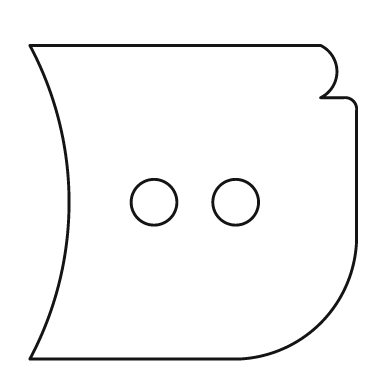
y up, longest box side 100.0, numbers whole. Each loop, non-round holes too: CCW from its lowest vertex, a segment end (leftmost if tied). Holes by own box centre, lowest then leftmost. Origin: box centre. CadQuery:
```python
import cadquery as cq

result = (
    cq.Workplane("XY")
    .moveTo(-50.0, -48.0)
    .lineTo(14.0, -48.0)
    .threePointArc((39.0, -37.0), (50.0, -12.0))
    .lineTo(50.0, 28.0)
    .threePointArc((49.0, 31.0), (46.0, 32.0))
    .lineTo(39.0, 32.0)
    .threePointArc((44.0, 40.0), (39.0, 48.0))
    .lineTo(-50.0, 48.0)
    .threePointArc((-38.0, 0.0), (-50.0, -48.0))
    .close()
    .moveTo(-12.0, 0.0)
    .circle(7.0)
    .moveTo(13.0, 0.0)
    .circle(7.0)
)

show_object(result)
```